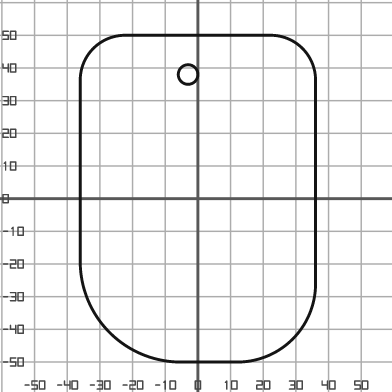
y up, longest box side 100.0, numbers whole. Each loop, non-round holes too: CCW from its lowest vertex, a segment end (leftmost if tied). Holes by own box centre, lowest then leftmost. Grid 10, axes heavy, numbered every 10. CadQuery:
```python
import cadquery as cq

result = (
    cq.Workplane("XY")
    .moveTo(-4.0, -50.0)
    .lineTo(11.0, -50.0)
    .threePointArc((29.0, -43.0), (36.0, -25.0))
    .lineTo(36.0, 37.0)
    .threePointArc((32.0, 46.0), (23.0, 50.0))
    .lineTo(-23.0, 50.0)
    .threePointArc((-32.0, 46.0), (-36.0, 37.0))
    .lineTo(-36.0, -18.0)
    .threePointArc((-27.0, -41.0), (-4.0, -50.0))
    .close()
    .moveTo(-3.0, 38.0)
    .circle(3.0)
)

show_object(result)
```